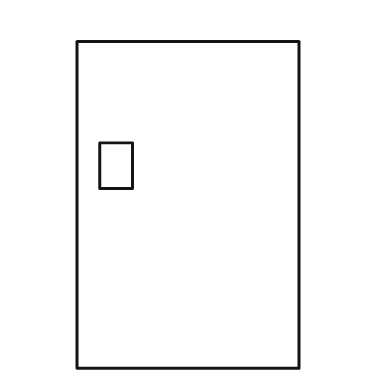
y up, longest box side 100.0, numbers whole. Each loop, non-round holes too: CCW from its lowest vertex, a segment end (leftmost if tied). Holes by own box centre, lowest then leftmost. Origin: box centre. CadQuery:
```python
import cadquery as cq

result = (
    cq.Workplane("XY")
    .moveTo(-34.0, -50.0)
    .lineTo(34.0, -50.0)
    .lineTo(34.0, 50.0)
    .lineTo(-34.0, 50.0)
    .close()
    .moveTo(-27.0, 5.0)
    .lineTo(-17.0, 5.0)
    .lineTo(-17.0, 19.0)
    .lineTo(-27.0, 19.0)
    .close()
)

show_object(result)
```